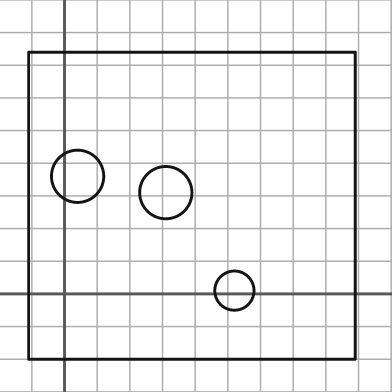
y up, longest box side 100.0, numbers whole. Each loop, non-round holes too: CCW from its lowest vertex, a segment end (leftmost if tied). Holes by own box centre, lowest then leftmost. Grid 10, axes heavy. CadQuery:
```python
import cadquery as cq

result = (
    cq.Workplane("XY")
    .moveTo(-11.0, -20.0)
    .lineTo(89.0, -20.0)
    .lineTo(89.0, 74.0)
    .lineTo(-11.0, 74.0)
    .close()
    .moveTo(52.0, 1.0)
    .circle(6.0)
    .moveTo(31.0, 31.0)
    .circle(8.0)
    .moveTo(4.0, 36.0)
    .circle(8.0)
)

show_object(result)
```